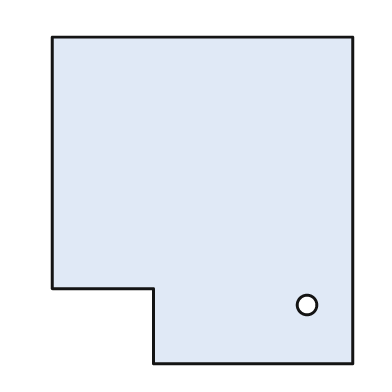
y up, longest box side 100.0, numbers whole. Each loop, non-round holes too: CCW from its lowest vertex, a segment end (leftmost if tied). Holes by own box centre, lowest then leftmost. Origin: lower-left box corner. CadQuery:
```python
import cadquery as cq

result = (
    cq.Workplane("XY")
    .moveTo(31.0, 0.0)
    .lineTo(92.0, 0.0)
    .lineTo(92.0, 100.0)
    .lineTo(0.0, 100.0)
    .lineTo(0.0, 23.0)
    .lineTo(31.0, 23.0)
    .close()
    .moveTo(78.0, 18.0)
    .circle(3.0)
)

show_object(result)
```